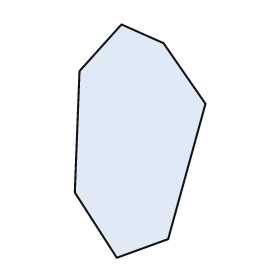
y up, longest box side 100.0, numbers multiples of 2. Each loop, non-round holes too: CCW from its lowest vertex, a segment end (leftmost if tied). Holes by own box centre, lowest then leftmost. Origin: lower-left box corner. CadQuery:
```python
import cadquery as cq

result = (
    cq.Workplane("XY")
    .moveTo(18.0, 0.0)
    .lineTo(40.0, 8.0)
    .lineTo(56.0, 66.0)
    .lineTo(38.0, 92.0)
    .lineTo(20.0, 100.0)
    .lineTo(2.0, 80.0)
    .lineTo(0.0, 28.0)
    .close()
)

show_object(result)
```